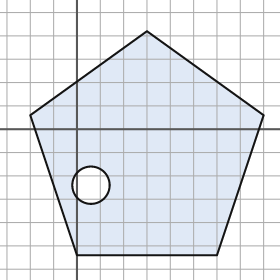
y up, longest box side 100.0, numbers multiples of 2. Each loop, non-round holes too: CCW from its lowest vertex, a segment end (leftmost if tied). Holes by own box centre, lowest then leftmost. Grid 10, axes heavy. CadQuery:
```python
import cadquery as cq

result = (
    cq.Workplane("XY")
    .moveTo(0.0, -54.0)
    .lineTo(60.0, -54.0)
    .lineTo(80.0, 6.0)
    .lineTo(30.0, 42.0)
    .lineTo(-20.0, 6.0)
    .close()
    .moveTo(6.0, -24.0)
    .circle(8.0)
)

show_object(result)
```